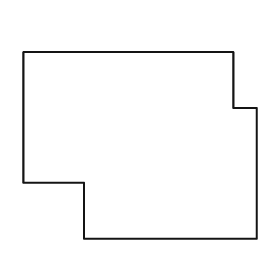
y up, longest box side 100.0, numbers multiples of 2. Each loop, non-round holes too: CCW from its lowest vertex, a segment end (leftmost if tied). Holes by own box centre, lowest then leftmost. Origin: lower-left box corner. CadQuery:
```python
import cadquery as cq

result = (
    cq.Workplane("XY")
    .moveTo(26.0, 0.0)
    .lineTo(100.0, 0.0)
    .lineTo(100.0, 56.0)
    .lineTo(90.0, 56.0)
    .lineTo(90.0, 80.0)
    .lineTo(0.0, 80.0)
    .lineTo(0.0, 24.0)
    .lineTo(26.0, 24.0)
    .close()
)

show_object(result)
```